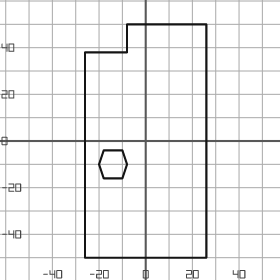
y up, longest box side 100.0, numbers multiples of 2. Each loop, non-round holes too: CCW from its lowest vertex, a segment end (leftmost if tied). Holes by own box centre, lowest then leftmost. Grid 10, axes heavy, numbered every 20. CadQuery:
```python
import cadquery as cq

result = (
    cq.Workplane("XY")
    .moveTo(-26.0, -50.0)
    .lineTo(26.0, -50.0)
    .lineTo(26.0, 50.0)
    .lineTo(-8.0, 50.0)
    .lineTo(-8.0, 38.0)
    .lineTo(-26.0, 38.0)
    .close()
    .moveTo(-18.0, -16.0)
    .lineTo(-10.0, -16.0)
    .lineTo(-8.0, -10.0)
    .lineTo(-10.0, -4.0)
    .lineTo(-18.0, -4.0)
    .lineTo(-20.0, -10.0)
    .close()
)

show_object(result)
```